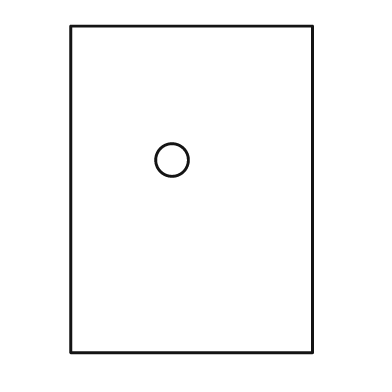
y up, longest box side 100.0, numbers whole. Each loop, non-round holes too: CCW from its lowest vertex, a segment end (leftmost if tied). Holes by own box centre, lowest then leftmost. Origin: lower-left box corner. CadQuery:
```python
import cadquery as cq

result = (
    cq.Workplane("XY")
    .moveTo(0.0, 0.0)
    .lineTo(74.0, 0.0)
    .lineTo(74.0, 100.0)
    .lineTo(0.0, 100.0)
    .close()
    .moveTo(31.0, 59.0)
    .circle(5.0)
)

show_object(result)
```